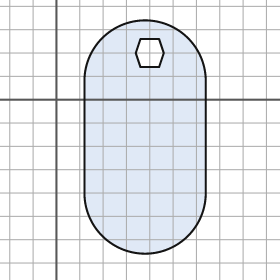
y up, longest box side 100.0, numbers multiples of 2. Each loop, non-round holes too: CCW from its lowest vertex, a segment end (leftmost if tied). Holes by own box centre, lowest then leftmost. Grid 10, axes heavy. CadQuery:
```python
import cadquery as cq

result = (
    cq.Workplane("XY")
    .moveTo(12.0, -40.0)
    .threePointArc((38.0, -66.0), (64.0, -40.0))
    .lineTo(64.0, 8.0)
    .threePointArc((38.0, 34.0), (12.0, 8.0))
    .close()
    .moveTo(36.0, 14.0)
    .lineTo(44.0, 14.0)
    .lineTo(46.0, 20.0)
    .lineTo(44.0, 26.0)
    .lineTo(36.0, 26.0)
    .lineTo(34.0, 20.0)
    .close()
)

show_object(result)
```